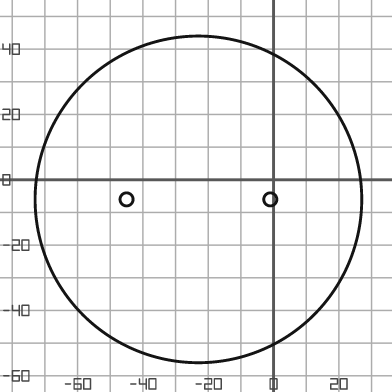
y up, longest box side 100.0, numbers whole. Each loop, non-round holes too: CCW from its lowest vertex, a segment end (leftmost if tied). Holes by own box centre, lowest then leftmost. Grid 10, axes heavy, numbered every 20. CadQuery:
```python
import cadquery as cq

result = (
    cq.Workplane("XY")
    .moveTo(-23.0, -6.0)
    .circle(50.0)
    .moveTo(-45.0, -6.0)
    .circle(2.0)
    .moveTo(-1.0, -6.0)
    .circle(2.0)
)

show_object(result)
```